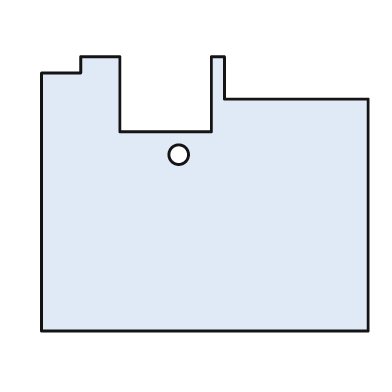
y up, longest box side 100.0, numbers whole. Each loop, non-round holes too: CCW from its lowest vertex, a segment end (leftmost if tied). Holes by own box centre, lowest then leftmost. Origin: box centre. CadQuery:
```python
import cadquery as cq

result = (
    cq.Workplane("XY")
    .moveTo(-50.0, -42.0)
    .lineTo(50.0, -42.0)
    .lineTo(50.0, 29.0)
    .lineTo(6.0, 29.0)
    .lineTo(6.0, 42.0)
    .lineTo(2.0, 42.0)
    .lineTo(2.0, 19.0)
    .lineTo(-26.0, 19.0)
    .lineTo(-26.0, 42.0)
    .lineTo(-38.0, 42.0)
    .lineTo(-38.0, 37.0)
    .lineTo(-50.0, 37.0)
    .close()
    .moveTo(-8.0, 12.0)
    .circle(3.0)
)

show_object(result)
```